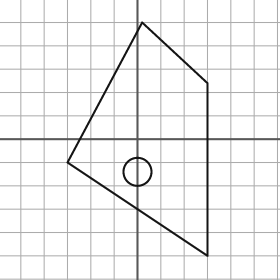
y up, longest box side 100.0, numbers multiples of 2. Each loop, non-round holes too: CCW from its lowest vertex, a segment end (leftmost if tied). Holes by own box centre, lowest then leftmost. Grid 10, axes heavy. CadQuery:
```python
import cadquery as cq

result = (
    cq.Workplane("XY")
    .moveTo(30.0, -50.0)
    .lineTo(30.0, 24.0)
    .lineTo(2.0, 50.0)
    .lineTo(-30.0, -10.0)
    .close()
    .moveTo(0.0, -14.0)
    .circle(6.0)
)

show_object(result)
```